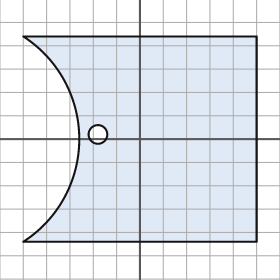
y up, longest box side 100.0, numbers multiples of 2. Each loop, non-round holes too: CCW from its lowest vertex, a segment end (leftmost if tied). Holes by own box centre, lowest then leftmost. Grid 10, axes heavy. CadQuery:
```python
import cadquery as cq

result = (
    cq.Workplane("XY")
    .moveTo(-50.0, -44.0)
    .lineTo(50.0, -44.0)
    .lineTo(50.0, 44.0)
    .lineTo(-50.0, 44.0)
    .threePointArc((-26.0, 0.0), (-50.0, -44.0))
    .close()
    .moveTo(-18.0, 2.0)
    .circle(4.0)
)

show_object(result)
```